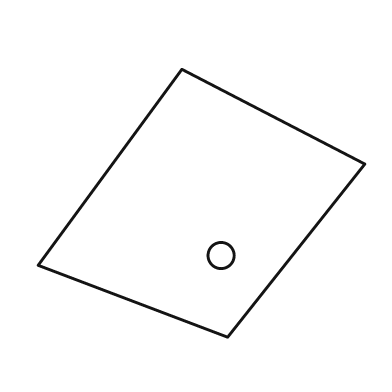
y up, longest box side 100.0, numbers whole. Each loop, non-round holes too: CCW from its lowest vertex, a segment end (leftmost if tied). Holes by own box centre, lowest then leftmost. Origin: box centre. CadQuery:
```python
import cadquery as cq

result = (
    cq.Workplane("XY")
    .moveTo(8.0, -41.0)
    .lineTo(50.0, 12.0)
    .lineTo(-6.0, 41.0)
    .lineTo(-50.0, -19.0)
    .close()
    .moveTo(6.0, -16.0)
    .circle(4.0)
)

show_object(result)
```